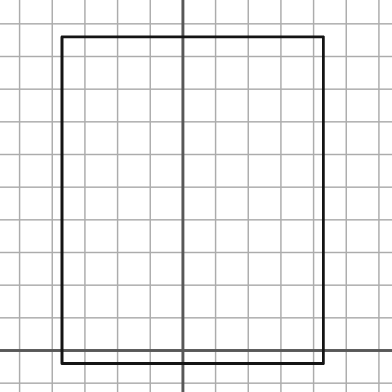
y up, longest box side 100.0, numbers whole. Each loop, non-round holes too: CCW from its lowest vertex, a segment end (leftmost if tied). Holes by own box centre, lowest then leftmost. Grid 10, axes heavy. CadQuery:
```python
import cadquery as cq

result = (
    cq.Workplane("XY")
    .moveTo(-37.0, -4.0)
    .lineTo(43.0, -4.0)
    .lineTo(43.0, 96.0)
    .lineTo(-37.0, 96.0)
    .close()
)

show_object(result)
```